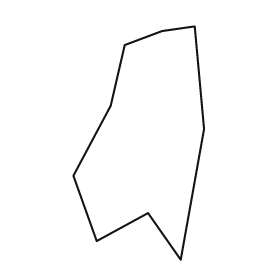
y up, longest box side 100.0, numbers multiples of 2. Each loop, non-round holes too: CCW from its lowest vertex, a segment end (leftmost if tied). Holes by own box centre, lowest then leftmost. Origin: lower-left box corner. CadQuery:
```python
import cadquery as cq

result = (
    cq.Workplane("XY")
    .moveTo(46.0, 0.0)
    .lineTo(56.0, 56.0)
    .lineTo(52.0, 100.0)
    .lineTo(38.0, 98.0)
    .lineTo(22.0, 92.0)
    .lineTo(16.0, 66.0)
    .lineTo(0.0, 36.0)
    .lineTo(10.0, 8.0)
    .lineTo(32.0, 20.0)
    .close()
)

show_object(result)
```